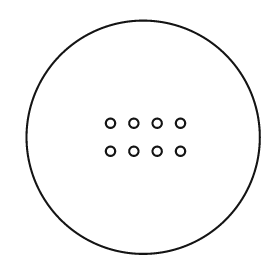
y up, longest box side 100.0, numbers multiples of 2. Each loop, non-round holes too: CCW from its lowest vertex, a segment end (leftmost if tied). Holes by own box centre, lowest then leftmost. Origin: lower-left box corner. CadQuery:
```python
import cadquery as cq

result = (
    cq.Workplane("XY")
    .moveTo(50.0, 50.0)
    .circle(50.0)
    .moveTo(36.0, 44.0)
    .circle(2.0)
    .moveTo(46.0, 44.0)
    .circle(2.0)
    .moveTo(56.0, 44.0)
    .circle(2.0)
    .moveTo(66.0, 44.0)
    .circle(2.0)
    .moveTo(36.0, 56.0)
    .circle(2.0)
    .moveTo(46.0, 56.0)
    .circle(2.0)
    .moveTo(56.0, 56.0)
    .circle(2.0)
    .moveTo(66.0, 56.0)
    .circle(2.0)
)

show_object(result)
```